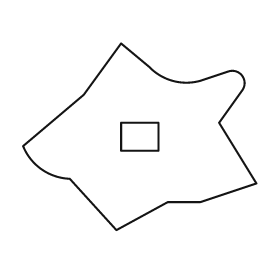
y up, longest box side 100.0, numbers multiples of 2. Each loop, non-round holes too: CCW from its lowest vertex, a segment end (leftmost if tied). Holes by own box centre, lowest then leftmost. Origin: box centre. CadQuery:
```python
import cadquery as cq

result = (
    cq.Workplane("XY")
    .moveTo(-10.0, -40.0)
    .lineTo(12.0, -28.0)
    .lineTo(26.0, -28.0)
    .lineTo(50.0, -20.0)
    .lineTo(34.0, 6.0)
    .lineTo(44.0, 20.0)
    .threePointArc((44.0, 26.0), (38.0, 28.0))
    .lineTo(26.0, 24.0)
    .threePointArc((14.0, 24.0), (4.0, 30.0))
    .lineTo(-8.0, 40.0)
    .lineTo(-24.0, 18.0)
    .lineTo(-50.0, -4.0)
    .threePointArc((-42.0, -14.0), (-30.0, -18.0))
    .close()
    .moveTo(-8.0, -6.0)
    .lineTo(8.0, -6.0)
    .lineTo(8.0, 6.0)
    .lineTo(-8.0, 6.0)
    .close()
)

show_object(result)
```